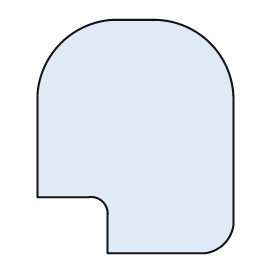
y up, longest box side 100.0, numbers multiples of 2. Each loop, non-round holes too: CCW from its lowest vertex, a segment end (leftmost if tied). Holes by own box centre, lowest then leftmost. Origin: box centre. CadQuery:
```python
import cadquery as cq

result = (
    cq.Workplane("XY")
    .moveTo(-12.0, -50.0)
    .lineTo(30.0, -50.0)
    .threePointArc((38.0, -46.0), (42.0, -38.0))
    .lineTo(42.0, 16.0)
    .threePointArc((32.0, 40.0), (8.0, 50.0))
    .lineTo(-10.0, 50.0)
    .threePointArc((-32.0, 40.0), (-42.0, 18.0))
    .lineTo(-42.0, -26.0)
    .lineTo(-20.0, -26.0)
    .threePointArc((-14.0, -28.0), (-12.0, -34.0))
    .close()
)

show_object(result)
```